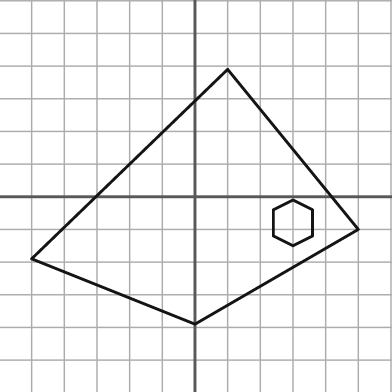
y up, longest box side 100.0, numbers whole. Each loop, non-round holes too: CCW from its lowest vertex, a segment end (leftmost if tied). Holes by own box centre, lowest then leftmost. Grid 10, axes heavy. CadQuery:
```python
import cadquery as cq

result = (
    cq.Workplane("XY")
    .moveTo(0.0, -39.0)
    .lineTo(50.0, -10.0)
    .lineTo(10.0, 39.0)
    .lineTo(-50.0, -19.0)
    .close()
    .moveTo(30.0, -15.0)
    .lineTo(36.0, -12.0)
    .lineTo(36.0, -4.0)
    .lineTo(30.0, -1.0)
    .lineTo(24.0, -4.0)
    .lineTo(24.0, -12.0)
    .close()
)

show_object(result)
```